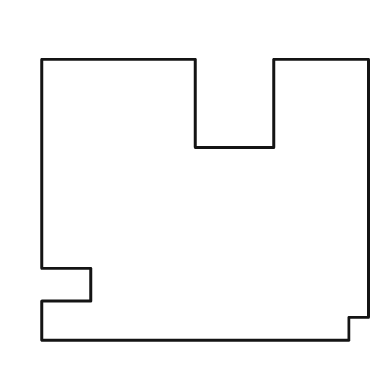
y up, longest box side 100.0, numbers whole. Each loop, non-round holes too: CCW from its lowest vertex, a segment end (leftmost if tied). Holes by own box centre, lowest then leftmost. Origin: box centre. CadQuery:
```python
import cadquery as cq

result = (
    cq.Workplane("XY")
    .moveTo(-50.0, -43.0)
    .lineTo(44.0, -43.0)
    .lineTo(44.0, -36.0)
    .lineTo(50.0, -36.0)
    .lineTo(50.0, 43.0)
    .lineTo(21.0, 43.0)
    .lineTo(21.0, 16.0)
    .lineTo(-3.0, 16.0)
    .lineTo(-3.0, 43.0)
    .lineTo(-50.0, 43.0)
    .lineTo(-50.0, -21.0)
    .lineTo(-35.0, -21.0)
    .lineTo(-35.0, -31.0)
    .lineTo(-50.0, -31.0)
    .close()
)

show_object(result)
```